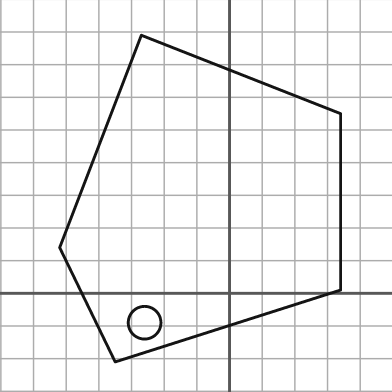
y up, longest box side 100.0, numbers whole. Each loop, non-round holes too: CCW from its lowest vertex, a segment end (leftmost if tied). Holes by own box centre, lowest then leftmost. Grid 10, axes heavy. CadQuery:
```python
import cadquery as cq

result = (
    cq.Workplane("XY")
    .moveTo(-35.0, -21.0)
    .lineTo(34.0, 1.0)
    .lineTo(34.0, 55.0)
    .lineTo(-27.0, 79.0)
    .lineTo(-52.0, 14.0)
    .close()
    .moveTo(-26.0, -9.0)
    .circle(5.0)
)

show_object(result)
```